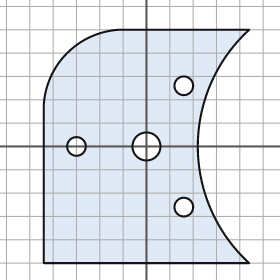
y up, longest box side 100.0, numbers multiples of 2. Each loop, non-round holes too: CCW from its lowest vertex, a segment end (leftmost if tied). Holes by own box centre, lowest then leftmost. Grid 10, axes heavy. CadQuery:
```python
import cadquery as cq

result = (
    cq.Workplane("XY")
    .moveTo(-44.0, -50.0)
    .lineTo(44.0, -50.0)
    .threePointArc((22.0, 0.0), (44.0, 50.0))
    .lineTo(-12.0, 50.0)
    .threePointArc((-34.0, 40.0), (-44.0, 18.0))
    .close()
    .moveTo(16.0, -26.0)
    .circle(4.0)
    .moveTo(-30.0, 0.0)
    .circle(4.0)
    .moveTo(0.0, 0.0)
    .circle(6.0)
    .moveTo(16.0, 26.0)
    .circle(4.0)
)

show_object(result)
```